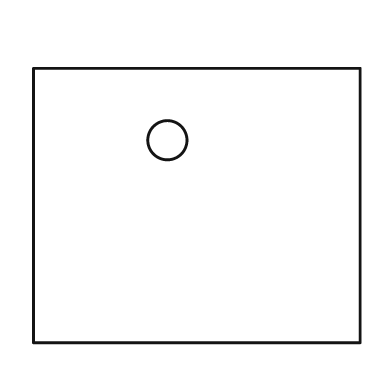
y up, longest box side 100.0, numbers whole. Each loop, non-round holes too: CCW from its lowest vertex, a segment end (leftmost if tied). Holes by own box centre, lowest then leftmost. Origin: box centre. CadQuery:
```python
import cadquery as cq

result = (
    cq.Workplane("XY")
    .moveTo(-50.0, -42.0)
    .lineTo(50.0, -42.0)
    .lineTo(50.0, 42.0)
    .lineTo(-50.0, 42.0)
    .close()
    .moveTo(-9.0, 20.0)
    .circle(6.0)
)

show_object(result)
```